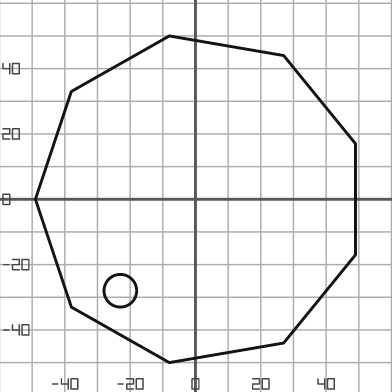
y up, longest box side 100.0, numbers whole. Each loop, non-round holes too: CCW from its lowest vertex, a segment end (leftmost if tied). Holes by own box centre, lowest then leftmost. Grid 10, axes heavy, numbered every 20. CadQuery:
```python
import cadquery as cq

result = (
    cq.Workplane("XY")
    .moveTo(-8.0, -50.0)
    .lineTo(27.0, -44.0)
    .lineTo(49.0, -17.0)
    .lineTo(49.0, 17.0)
    .lineTo(27.0, 44.0)
    .lineTo(-8.0, 50.0)
    .lineTo(-38.0, 33.0)
    .lineTo(-49.0, 0.0)
    .lineTo(-38.0, -33.0)
    .close()
    .moveTo(-23.0, -28.0)
    .circle(5.0)
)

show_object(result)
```